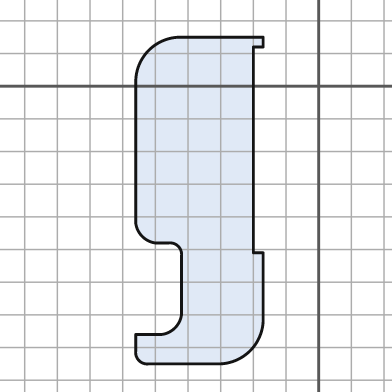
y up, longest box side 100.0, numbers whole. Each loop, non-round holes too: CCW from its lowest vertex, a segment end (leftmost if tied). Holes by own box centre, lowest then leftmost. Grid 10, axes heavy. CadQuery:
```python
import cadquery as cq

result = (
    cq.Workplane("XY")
    .moveTo(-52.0, -85.0)
    .lineTo(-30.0, -85.0)
    .threePointArc((-21.0, -81.0), (-17.0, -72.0))
    .lineTo(-17.0, -51.0)
    .lineTo(-20.0, -51.0)
    .lineTo(-20.0, 12.0)
    .lineTo(-17.0, 12.0)
    .lineTo(-17.0, 15.0)
    .lineTo(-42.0, 15.0)
    .threePointArc((-52.0, 11.0), (-56.0, 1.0))
    .lineTo(-56.0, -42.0)
    .threePointArc((-54.0, -46.0), (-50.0, -48.0))
    .lineTo(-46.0, -48.0)
    .threePointArc((-43.0, -49.0), (-42.0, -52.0))
    .lineTo(-42.0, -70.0)
    .threePointArc((-44.0, -74.0), (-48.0, -76.0))
    .lineTo(-56.0, -76.0)
    .lineTo(-56.0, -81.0)
    .threePointArc((-55.0, -84.0), (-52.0, -85.0))
    .close()
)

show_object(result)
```